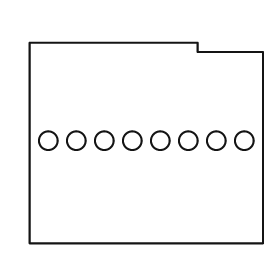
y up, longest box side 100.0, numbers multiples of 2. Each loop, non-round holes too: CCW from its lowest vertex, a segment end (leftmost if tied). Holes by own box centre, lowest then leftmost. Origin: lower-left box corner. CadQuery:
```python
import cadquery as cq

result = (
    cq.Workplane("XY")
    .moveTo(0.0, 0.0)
    .lineTo(100.0, 0.0)
    .lineTo(100.0, 82.0)
    .lineTo(72.0, 82.0)
    .lineTo(72.0, 86.0)
    .lineTo(0.0, 86.0)
    .close()
    .moveTo(8.0, 44.0)
    .circle(4.0)
    .moveTo(20.0, 44.0)
    .circle(4.0)
    .moveTo(32.0, 44.0)
    .circle(4.0)
    .moveTo(44.0, 44.0)
    .circle(4.0)
    .moveTo(56.0, 44.0)
    .circle(4.0)
    .moveTo(68.0, 44.0)
    .circle(4.0)
    .moveTo(80.0, 44.0)
    .circle(4.0)
    .moveTo(92.0, 44.0)
    .circle(4.0)
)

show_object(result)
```